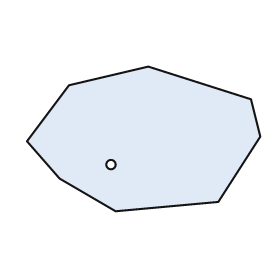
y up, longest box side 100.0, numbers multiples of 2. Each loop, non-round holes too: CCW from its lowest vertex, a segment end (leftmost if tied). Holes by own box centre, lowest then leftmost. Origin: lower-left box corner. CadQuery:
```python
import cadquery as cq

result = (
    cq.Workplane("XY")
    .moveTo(38.0, 0.0)
    .lineTo(82.0, 4.0)
    .lineTo(100.0, 32.0)
    .lineTo(96.0, 48.0)
    .lineTo(52.0, 62.0)
    .lineTo(18.0, 54.0)
    .lineTo(0.0, 30.0)
    .lineTo(14.0, 14.0)
    .close()
    .moveTo(36.0, 20.0)
    .circle(2.0)
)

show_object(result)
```